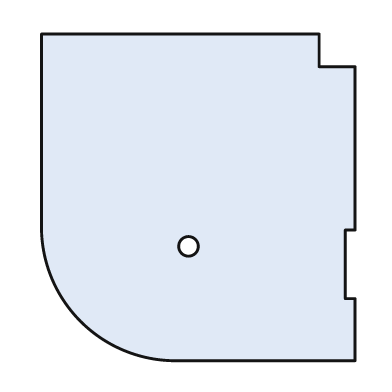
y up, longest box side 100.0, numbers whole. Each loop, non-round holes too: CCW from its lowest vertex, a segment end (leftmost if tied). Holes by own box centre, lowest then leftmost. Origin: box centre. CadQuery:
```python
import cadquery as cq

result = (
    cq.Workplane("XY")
    .moveTo(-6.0, -50.0)
    .lineTo(48.0, -50.0)
    .lineTo(48.0, -31.0)
    .lineTo(45.0, -31.0)
    .lineTo(45.0, -10.0)
    .lineTo(48.0, -10.0)
    .lineTo(48.0, 40.0)
    .lineTo(37.0, 40.0)
    .lineTo(37.0, 50.0)
    .lineTo(-48.0, 50.0)
    .lineTo(-48.0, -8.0)
    .threePointArc((-36.0, -38.0), (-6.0, -50.0))
    .close()
    .moveTo(-3.0, -15.0)
    .circle(3.0)
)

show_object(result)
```